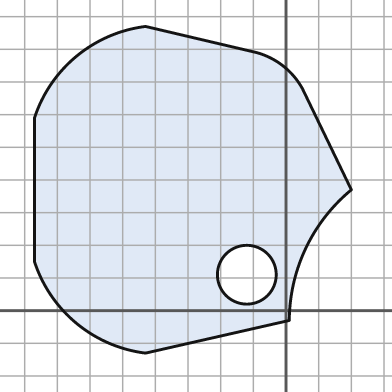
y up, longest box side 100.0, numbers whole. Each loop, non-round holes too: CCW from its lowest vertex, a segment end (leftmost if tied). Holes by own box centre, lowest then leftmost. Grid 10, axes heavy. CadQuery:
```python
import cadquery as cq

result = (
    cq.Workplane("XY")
    .moveTo(-43.0, -13.0)
    .lineTo(1.0, -3.0)
    .threePointArc((6.0, 19.0), (20.0, 37.0))
    .lineTo(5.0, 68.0)
    .threePointArc((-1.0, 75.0), (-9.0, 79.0))
    .lineTo(-43.0, 87.0)
    .threePointArc((-64.0, 78.0), (-77.0, 59.0))
    .lineTo(-77.0, 15.0)
    .threePointArc((-64.0, -4.0), (-43.0, -13.0))
    .close()
    .moveTo(-12.0, 11.0)
    .circle(9.0)
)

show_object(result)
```